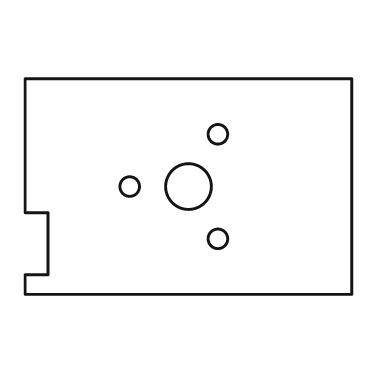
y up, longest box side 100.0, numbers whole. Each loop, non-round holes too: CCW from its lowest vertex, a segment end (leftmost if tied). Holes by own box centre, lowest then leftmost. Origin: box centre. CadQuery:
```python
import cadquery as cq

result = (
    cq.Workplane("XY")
    .moveTo(-50.0, -33.0)
    .lineTo(50.0, -33.0)
    .lineTo(50.0, 33.0)
    .lineTo(-50.0, 33.0)
    .lineTo(-50.0, -8.0)
    .lineTo(-43.0, -8.0)
    .lineTo(-43.0, -27.0)
    .lineTo(-50.0, -27.0)
    .close()
    .moveTo(9.0, -16.0)
    .circle(3.0)
    .moveTo(-18.0, 0.0)
    .circle(3.0)
    .moveTo(0.0, 0.0)
    .circle(7.0)
    .moveTo(9.0, 16.0)
    .circle(3.0)
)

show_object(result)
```